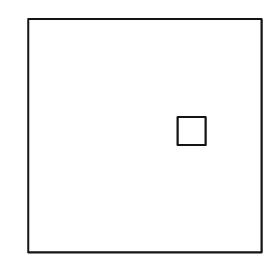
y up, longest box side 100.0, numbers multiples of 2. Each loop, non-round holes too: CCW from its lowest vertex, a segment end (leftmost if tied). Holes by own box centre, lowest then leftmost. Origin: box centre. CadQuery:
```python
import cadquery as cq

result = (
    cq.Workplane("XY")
    .moveTo(-50.0, -50.0)
    .lineTo(50.0, -50.0)
    .lineTo(50.0, 50.0)
    .lineTo(-50.0, 50.0)
    .close()
    .moveTo(14.0, -4.0)
    .lineTo(26.0, -4.0)
    .lineTo(26.0, 8.0)
    .lineTo(14.0, 8.0)
    .close()
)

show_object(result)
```